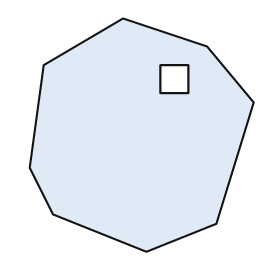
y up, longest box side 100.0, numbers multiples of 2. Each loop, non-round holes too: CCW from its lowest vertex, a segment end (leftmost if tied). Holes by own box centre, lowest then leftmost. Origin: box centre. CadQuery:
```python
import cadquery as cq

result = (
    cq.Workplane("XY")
    .moveTo(2.0, -50.0)
    .lineTo(32.0, -38.0)
    .lineTo(48.0, 14.0)
    .lineTo(28.0, 38.0)
    .lineTo(-8.0, 50.0)
    .lineTo(-42.0, 30.0)
    .lineTo(-48.0, -14.0)
    .lineTo(-38.0, -34.0)
    .close()
    .moveTo(8.0, 18.0)
    .lineTo(20.0, 18.0)
    .lineTo(20.0, 30.0)
    .lineTo(8.0, 30.0)
    .close()
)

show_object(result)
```